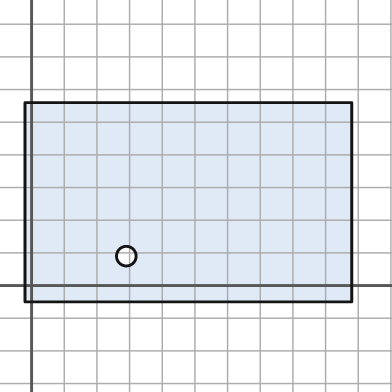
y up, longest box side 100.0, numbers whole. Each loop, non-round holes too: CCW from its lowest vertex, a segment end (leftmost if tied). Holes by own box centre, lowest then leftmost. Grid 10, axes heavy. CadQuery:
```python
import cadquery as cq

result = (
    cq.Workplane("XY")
    .moveTo(-2.0, -5.0)
    .lineTo(98.0, -5.0)
    .lineTo(98.0, 56.0)
    .lineTo(-2.0, 56.0)
    .close()
    .moveTo(29.0, 9.0)
    .circle(3.0)
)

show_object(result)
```